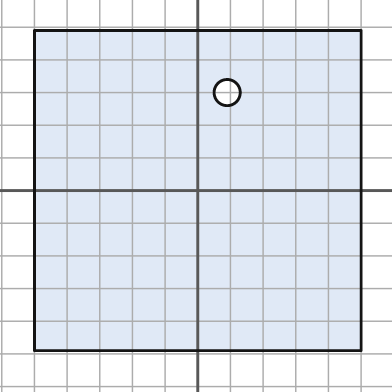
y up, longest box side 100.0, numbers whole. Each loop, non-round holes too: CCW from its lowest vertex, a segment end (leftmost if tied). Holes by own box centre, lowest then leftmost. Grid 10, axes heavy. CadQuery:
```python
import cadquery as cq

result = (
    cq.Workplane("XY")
    .moveTo(-50.0, -49.0)
    .lineTo(50.0, -49.0)
    .lineTo(50.0, 49.0)
    .lineTo(-50.0, 49.0)
    .close()
    .moveTo(9.0, 30.0)
    .circle(4.0)
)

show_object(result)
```